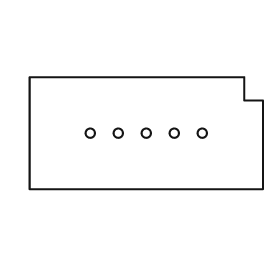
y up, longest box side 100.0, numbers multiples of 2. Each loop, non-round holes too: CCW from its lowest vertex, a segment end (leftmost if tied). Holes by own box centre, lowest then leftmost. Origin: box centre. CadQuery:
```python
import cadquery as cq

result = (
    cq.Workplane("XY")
    .moveTo(-50.0, -24.0)
    .lineTo(50.0, -24.0)
    .lineTo(50.0, 14.0)
    .lineTo(42.0, 14.0)
    .lineTo(42.0, 24.0)
    .lineTo(-50.0, 24.0)
    .close()
    .moveTo(-24.0, 0.0)
    .circle(2.0)
    .moveTo(-12.0, 0.0)
    .circle(2.0)
    .moveTo(0.0, 0.0)
    .circle(2.0)
    .moveTo(12.0, 0.0)
    .circle(2.0)
    .moveTo(24.0, 0.0)
    .circle(2.0)
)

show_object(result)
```